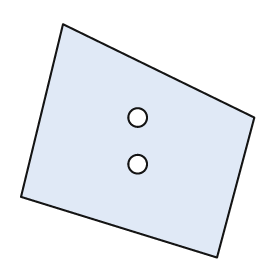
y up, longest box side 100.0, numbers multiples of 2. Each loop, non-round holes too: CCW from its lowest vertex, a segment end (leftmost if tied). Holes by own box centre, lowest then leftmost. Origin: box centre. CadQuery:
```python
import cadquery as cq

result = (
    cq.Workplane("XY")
    .moveTo(34.0, -50.0)
    .lineTo(50.0, 10.0)
    .lineTo(-32.0, 50.0)
    .lineTo(-50.0, -24.0)
    .close()
    .moveTo(0.0, -10.0)
    .circle(4.0)
    .moveTo(0.0, 10.0)
    .circle(4.0)
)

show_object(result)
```